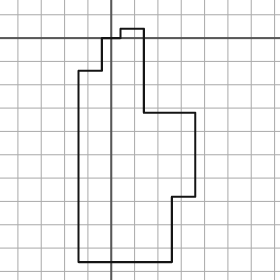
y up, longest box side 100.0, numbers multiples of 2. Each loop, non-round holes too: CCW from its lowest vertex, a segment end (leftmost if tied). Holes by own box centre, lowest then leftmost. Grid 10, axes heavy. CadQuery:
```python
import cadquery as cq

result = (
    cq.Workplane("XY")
    .moveTo(-14.0, -96.0)
    .lineTo(26.0, -96.0)
    .lineTo(26.0, -68.0)
    .lineTo(36.0, -68.0)
    .lineTo(36.0, -32.0)
    .lineTo(14.0, -32.0)
    .lineTo(14.0, 4.0)
    .lineTo(4.0, 4.0)
    .lineTo(4.0, 0.0)
    .lineTo(-4.0, 0.0)
    .lineTo(-4.0, -14.0)
    .lineTo(-14.0, -14.0)
    .close()
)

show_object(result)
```